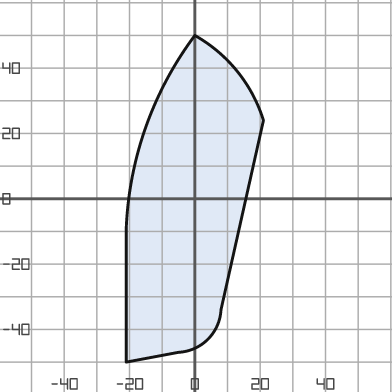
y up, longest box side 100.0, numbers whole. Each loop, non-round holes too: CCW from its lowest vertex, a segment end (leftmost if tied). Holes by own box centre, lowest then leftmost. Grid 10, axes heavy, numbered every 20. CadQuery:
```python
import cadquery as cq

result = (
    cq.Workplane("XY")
    .moveTo(-21.0, -50.0)
    .lineTo(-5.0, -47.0)
    .threePointArc((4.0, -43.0), (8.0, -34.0))
    .lineTo(21.0, 24.0)
    .threePointArc((13.0, 39.0), (0.0, 50.0))
    .threePointArc((-15.0, 22.0), (-21.0, -9.0))
    .close()
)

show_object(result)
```